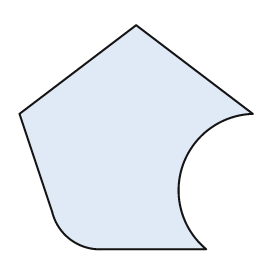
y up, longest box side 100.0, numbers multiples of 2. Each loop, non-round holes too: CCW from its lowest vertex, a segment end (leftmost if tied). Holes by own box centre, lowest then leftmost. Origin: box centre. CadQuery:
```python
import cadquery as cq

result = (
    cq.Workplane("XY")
    .moveTo(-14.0, -48.0)
    .lineTo(30.0, -48.0)
    .threePointArc((20.0, -12.0), (50.0, 10.0))
    .lineTo(0.0, 48.0)
    .lineTo(-50.0, 10.0)
    .lineTo(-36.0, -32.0)
    .threePointArc((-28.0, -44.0), (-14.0, -48.0))
    .close()
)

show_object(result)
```